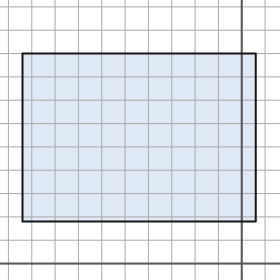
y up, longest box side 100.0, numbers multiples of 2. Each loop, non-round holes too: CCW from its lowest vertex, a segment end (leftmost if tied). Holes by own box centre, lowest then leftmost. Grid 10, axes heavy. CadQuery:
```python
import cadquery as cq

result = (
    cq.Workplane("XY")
    .moveTo(-94.0, 18.0)
    .lineTo(6.0, 18.0)
    .lineTo(6.0, 90.0)
    .lineTo(-94.0, 90.0)
    .close()
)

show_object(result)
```